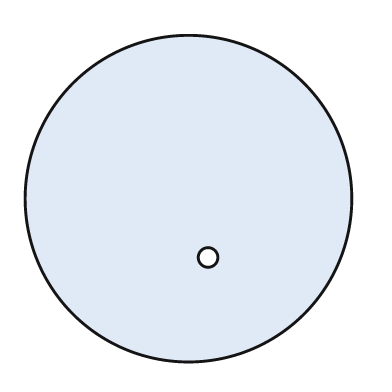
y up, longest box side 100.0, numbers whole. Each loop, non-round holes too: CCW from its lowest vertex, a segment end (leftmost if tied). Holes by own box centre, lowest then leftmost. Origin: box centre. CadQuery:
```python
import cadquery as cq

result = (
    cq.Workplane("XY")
    .moveTo(0.0, 0.0)
    .circle(50.0)
    .moveTo(6.0, -18.0)
    .circle(3.0)
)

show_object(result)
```